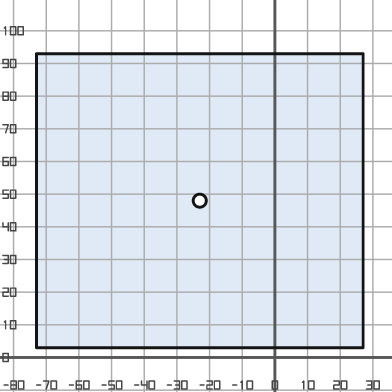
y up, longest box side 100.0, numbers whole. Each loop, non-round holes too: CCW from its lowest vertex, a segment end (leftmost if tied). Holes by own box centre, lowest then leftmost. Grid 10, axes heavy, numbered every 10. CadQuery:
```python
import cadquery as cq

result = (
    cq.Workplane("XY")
    .moveTo(-73.0, 3.0)
    .lineTo(27.0, 3.0)
    .lineTo(27.0, 93.0)
    .lineTo(-73.0, 93.0)
    .close()
    .moveTo(-23.0, 48.0)
    .circle(2.0)
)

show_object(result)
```